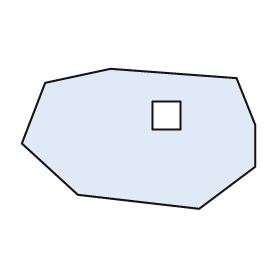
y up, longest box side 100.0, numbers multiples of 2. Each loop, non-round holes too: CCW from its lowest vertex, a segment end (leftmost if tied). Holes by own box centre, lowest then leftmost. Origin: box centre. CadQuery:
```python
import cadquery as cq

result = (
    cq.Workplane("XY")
    .moveTo(26.0, -30.0)
    .lineTo(50.0, -12.0)
    .lineTo(50.0, 6.0)
    .lineTo(42.0, 26.0)
    .lineTo(-12.0, 30.0)
    .lineTo(-40.0, 24.0)
    .lineTo(-50.0, -2.0)
    .lineTo(-26.0, -24.0)
    .close()
    .moveTo(6.0, 4.0)
    .lineTo(18.0, 4.0)
    .lineTo(18.0, 16.0)
    .lineTo(6.0, 16.0)
    .close()
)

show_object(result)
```